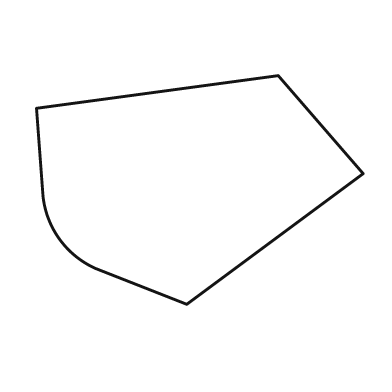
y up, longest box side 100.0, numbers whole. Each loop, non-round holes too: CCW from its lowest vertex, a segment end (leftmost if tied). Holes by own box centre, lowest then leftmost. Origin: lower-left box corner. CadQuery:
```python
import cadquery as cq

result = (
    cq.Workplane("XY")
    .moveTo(46.0, 0.0)
    .lineTo(100.0, 40.0)
    .lineTo(74.0, 70.0)
    .lineTo(0.0, 60.0)
    .lineTo(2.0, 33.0)
    .threePointArc((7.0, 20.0), (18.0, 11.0))
    .close()
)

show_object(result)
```